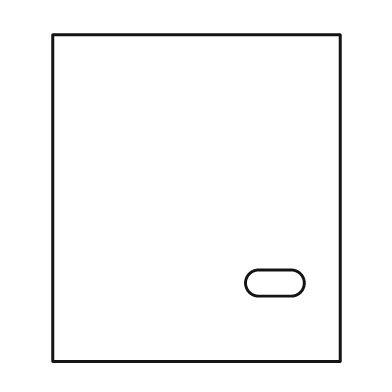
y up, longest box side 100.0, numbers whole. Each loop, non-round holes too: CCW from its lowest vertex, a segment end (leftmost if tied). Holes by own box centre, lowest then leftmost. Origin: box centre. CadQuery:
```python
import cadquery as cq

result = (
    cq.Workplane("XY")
    .moveTo(-44.0, -50.0)
    .lineTo(44.0, -50.0)
    .lineTo(44.0, 50.0)
    .lineTo(-44.0, 50.0)
    .close()
    .moveTo(19.0, -30.0)
    .lineTo(29.0, -30.0)
    .threePointArc((33.0, -26.0), (29.0, -22.0))
    .lineTo(19.0, -22.0)
    .threePointArc((15.0, -26.0), (19.0, -30.0))
    .close()
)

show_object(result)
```